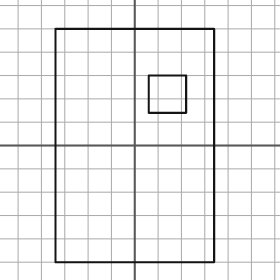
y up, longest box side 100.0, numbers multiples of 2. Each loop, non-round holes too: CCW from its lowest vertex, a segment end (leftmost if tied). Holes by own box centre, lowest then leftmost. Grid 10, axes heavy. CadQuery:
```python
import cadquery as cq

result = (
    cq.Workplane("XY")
    .moveTo(-34.0, -50.0)
    .lineTo(34.0, -50.0)
    .lineTo(34.0, 50.0)
    .lineTo(-34.0, 50.0)
    .close()
    .moveTo(6.0, 14.0)
    .lineTo(22.0, 14.0)
    .lineTo(22.0, 30.0)
    .lineTo(6.0, 30.0)
    .close()
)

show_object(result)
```